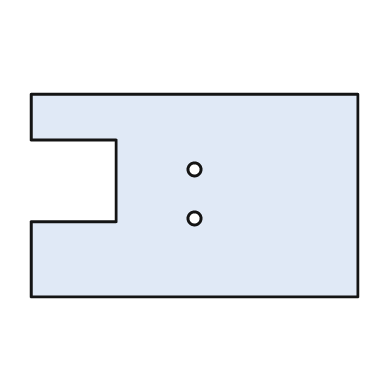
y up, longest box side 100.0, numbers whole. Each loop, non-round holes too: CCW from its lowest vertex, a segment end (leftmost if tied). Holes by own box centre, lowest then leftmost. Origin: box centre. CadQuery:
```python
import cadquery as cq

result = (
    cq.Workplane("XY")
    .moveTo(-50.0, -31.0)
    .lineTo(50.0, -31.0)
    .lineTo(50.0, 31.0)
    .lineTo(-50.0, 31.0)
    .lineTo(-50.0, 17.0)
    .lineTo(-24.0, 17.0)
    .lineTo(-24.0, -8.0)
    .lineTo(-50.0, -8.0)
    .close()
    .moveTo(0.0, -7.0)
    .circle(2.0)
    .moveTo(0.0, 8.0)
    .circle(2.0)
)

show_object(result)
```